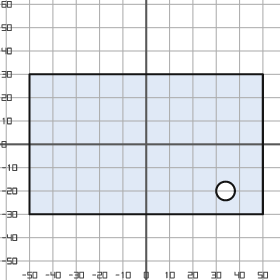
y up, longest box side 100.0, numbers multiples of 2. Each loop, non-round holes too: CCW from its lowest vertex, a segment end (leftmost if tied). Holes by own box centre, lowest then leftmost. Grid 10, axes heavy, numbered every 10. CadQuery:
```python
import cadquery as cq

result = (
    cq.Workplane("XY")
    .moveTo(-50.0, -30.0)
    .lineTo(50.0, -30.0)
    .lineTo(50.0, 30.0)
    .lineTo(-50.0, 30.0)
    .close()
    .moveTo(34.0, -20.0)
    .circle(4.0)
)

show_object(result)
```